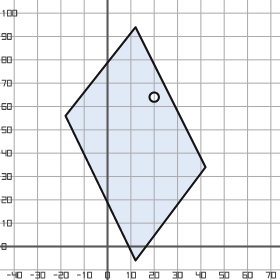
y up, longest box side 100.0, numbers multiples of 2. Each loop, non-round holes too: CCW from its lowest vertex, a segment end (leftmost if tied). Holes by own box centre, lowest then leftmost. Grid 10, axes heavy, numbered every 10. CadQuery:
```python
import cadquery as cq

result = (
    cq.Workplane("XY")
    .moveTo(12.0, -6.0)
    .lineTo(42.0, 34.0)
    .lineTo(12.0, 94.0)
    .lineTo(-18.0, 56.0)
    .close()
    .moveTo(20.0, 64.0)
    .circle(2.0)
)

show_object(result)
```